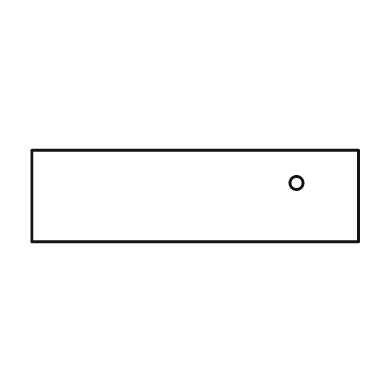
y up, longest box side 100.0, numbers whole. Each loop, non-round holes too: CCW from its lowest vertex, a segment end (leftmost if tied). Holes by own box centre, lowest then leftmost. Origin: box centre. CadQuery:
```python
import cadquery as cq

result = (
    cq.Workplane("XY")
    .moveTo(-50.0, -14.0)
    .lineTo(50.0, -14.0)
    .lineTo(50.0, 14.0)
    .lineTo(-50.0, 14.0)
    .close()
    .moveTo(31.0, 4.0)
    .circle(2.0)
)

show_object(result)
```